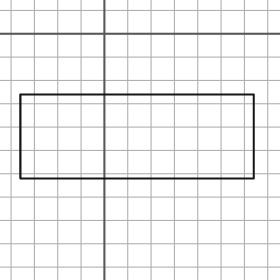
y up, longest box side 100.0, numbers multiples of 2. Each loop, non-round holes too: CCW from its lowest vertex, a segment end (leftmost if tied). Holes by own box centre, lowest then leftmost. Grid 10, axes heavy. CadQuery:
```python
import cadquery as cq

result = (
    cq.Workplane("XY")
    .moveTo(-36.0, -62.0)
    .lineTo(64.0, -62.0)
    .lineTo(64.0, -26.0)
    .lineTo(-36.0, -26.0)
    .close()
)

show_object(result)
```